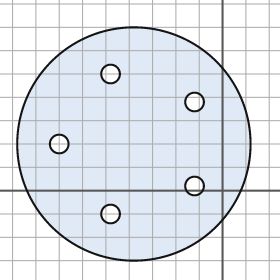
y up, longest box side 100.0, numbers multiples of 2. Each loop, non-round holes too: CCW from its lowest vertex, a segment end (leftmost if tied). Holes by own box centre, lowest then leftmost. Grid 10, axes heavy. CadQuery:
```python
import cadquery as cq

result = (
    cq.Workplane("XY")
    .moveTo(-38.0, 20.0)
    .circle(50.0)
    .moveTo(-48.0, -10.0)
    .circle(4.0)
    .moveTo(-12.0, 2.0)
    .circle(4.0)
    .moveTo(-70.0, 20.0)
    .circle(4.0)
    .moveTo(-12.0, 38.0)
    .circle(4.0)
    .moveTo(-48.0, 50.0)
    .circle(4.0)
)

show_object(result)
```